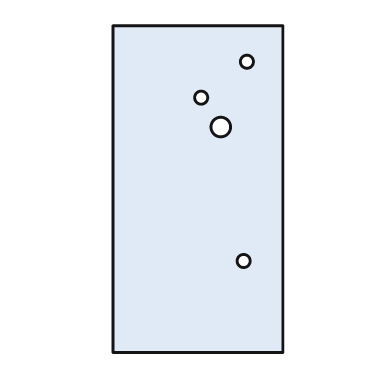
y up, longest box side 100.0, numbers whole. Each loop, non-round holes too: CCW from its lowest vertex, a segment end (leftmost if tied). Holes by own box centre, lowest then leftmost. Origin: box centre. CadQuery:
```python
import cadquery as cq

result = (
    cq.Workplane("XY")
    .moveTo(-26.0, -50.0)
    .lineTo(26.0, -50.0)
    .lineTo(26.0, 50.0)
    .lineTo(-26.0, 50.0)
    .close()
    .moveTo(14.0, -22.0)
    .circle(2.0)
    .moveTo(7.0, 19.0)
    .circle(3.0)
    .moveTo(1.0, 28.0)
    .circle(2.0)
    .moveTo(15.0, 39.0)
    .circle(2.0)
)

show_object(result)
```